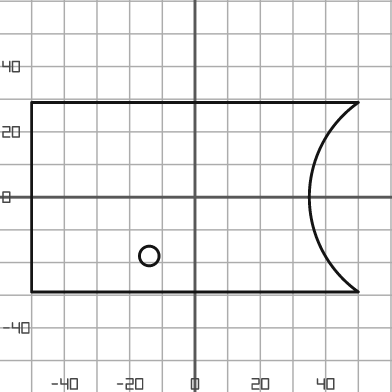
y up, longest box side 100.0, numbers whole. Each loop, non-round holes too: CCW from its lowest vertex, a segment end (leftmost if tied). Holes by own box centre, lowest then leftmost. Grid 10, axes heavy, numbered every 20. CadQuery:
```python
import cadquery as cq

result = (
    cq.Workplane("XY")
    .moveTo(-50.0, -29.0)
    .lineTo(50.0, -29.0)
    .threePointArc((35.0, 0.0), (50.0, 29.0))
    .lineTo(-50.0, 29.0)
    .close()
    .moveTo(-14.0, -18.0)
    .circle(3.0)
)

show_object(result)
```